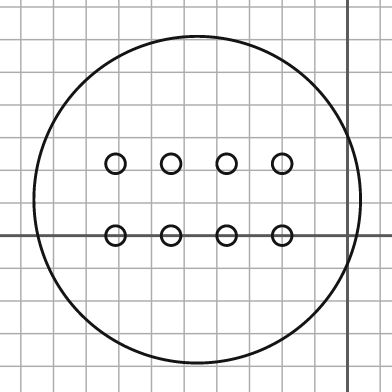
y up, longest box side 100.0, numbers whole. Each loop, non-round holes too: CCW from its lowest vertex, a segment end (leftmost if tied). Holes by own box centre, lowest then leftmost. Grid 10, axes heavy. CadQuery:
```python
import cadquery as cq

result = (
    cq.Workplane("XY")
    .moveTo(-46.0, 11.0)
    .circle(50.0)
    .moveTo(-71.0, 0.0)
    .circle(3.0)
    .moveTo(-54.0, 0.0)
    .circle(3.0)
    .moveTo(-37.0, 0.0)
    .circle(3.0)
    .moveTo(-20.0, 0.0)
    .circle(3.0)
    .moveTo(-71.0, 22.0)
    .circle(3.0)
    .moveTo(-54.0, 22.0)
    .circle(3.0)
    .moveTo(-37.0, 22.0)
    .circle(3.0)
    .moveTo(-20.0, 22.0)
    .circle(3.0)
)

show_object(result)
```